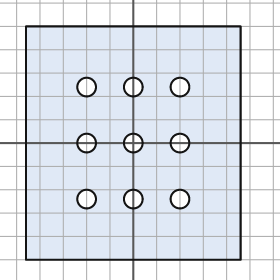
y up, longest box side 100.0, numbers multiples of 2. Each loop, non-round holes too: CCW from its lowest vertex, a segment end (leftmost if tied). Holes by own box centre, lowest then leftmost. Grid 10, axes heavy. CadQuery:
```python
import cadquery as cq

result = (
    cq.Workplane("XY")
    .moveTo(-46.0, -50.0)
    .lineTo(46.0, -50.0)
    .lineTo(46.0, 50.0)
    .lineTo(-46.0, 50.0)
    .close()
    .moveTo(-20.0, -24.0)
    .circle(4.0)
    .moveTo(0.0, -24.0)
    .circle(4.0)
    .moveTo(20.0, -24.0)
    .circle(4.0)
    .moveTo(-20.0, 0.0)
    .circle(4.0)
    .moveTo(0.0, 0.0)
    .circle(4.0)
    .moveTo(20.0, 0.0)
    .circle(4.0)
    .moveTo(-20.0, 24.0)
    .circle(4.0)
    .moveTo(0.0, 24.0)
    .circle(4.0)
    .moveTo(20.0, 24.0)
    .circle(4.0)
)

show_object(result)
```